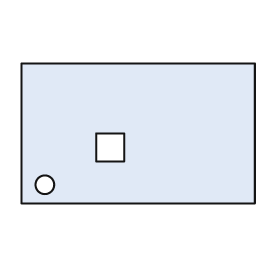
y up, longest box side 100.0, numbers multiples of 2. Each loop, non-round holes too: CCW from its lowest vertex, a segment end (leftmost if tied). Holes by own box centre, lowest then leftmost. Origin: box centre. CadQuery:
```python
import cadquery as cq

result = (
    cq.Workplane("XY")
    .moveTo(-50.0, -30.0)
    .lineTo(50.0, -30.0)
    .lineTo(50.0, 30.0)
    .lineTo(-50.0, 30.0)
    .close()
    .moveTo(-40.0, -22.0)
    .circle(4.0)
    .moveTo(-18.0, -12.0)
    .lineTo(-6.0, -12.0)
    .lineTo(-6.0, 0.0)
    .lineTo(-18.0, 0.0)
    .close()
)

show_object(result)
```